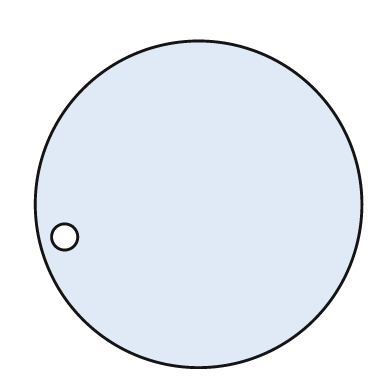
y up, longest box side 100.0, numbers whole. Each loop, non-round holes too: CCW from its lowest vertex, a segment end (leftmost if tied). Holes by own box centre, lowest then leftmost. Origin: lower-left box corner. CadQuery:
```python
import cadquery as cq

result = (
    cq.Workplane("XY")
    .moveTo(50.0, 50.0)
    .circle(50.0)
    .moveTo(9.0, 40.0)
    .circle(4.0)
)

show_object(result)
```